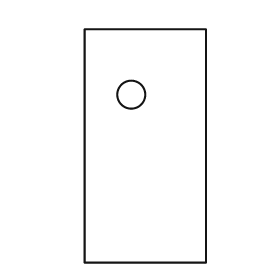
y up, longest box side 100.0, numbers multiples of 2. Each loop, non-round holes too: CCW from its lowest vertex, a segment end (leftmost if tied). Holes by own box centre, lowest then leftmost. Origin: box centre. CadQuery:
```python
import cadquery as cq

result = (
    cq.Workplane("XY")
    .moveTo(-26.0, -50.0)
    .lineTo(26.0, -50.0)
    .lineTo(26.0, 50.0)
    .lineTo(-26.0, 50.0)
    .close()
    .moveTo(-6.0, 22.0)
    .circle(6.0)
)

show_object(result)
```